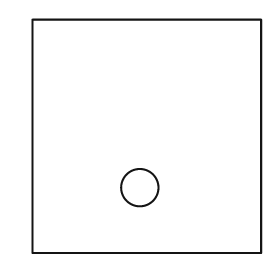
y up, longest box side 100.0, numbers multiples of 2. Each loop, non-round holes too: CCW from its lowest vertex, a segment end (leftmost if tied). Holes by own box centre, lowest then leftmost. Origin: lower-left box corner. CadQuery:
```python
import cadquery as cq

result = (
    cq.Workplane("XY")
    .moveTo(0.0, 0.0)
    .lineTo(98.0, 0.0)
    .lineTo(98.0, 100.0)
    .lineTo(0.0, 100.0)
    .close()
    .moveTo(46.0, 28.0)
    .circle(8.0)
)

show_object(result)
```